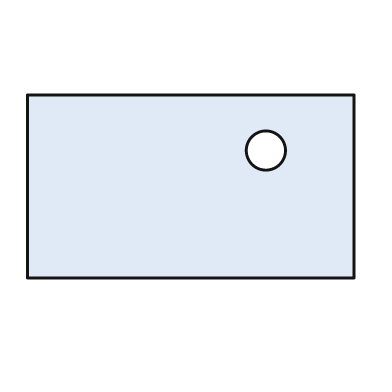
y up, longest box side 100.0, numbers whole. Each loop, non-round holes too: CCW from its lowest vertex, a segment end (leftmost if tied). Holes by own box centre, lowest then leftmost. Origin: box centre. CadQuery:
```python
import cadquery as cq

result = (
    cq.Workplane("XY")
    .moveTo(-50.0, -28.0)
    .lineTo(50.0, -28.0)
    .lineTo(50.0, 28.0)
    .lineTo(-50.0, 28.0)
    .close()
    .moveTo(23.0, 11.0)
    .circle(6.0)
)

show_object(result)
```